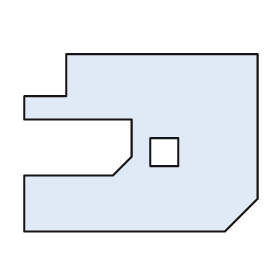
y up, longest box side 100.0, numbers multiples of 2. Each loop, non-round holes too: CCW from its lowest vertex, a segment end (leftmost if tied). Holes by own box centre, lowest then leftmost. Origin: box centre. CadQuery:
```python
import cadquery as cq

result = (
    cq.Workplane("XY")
    .moveTo(-50.0, -38.0)
    .lineTo(36.0, -38.0)
    .lineTo(50.0, -24.0)
    .lineTo(50.0, 38.0)
    .lineTo(-32.0, 38.0)
    .lineTo(-32.0, 20.0)
    .lineTo(-50.0, 20.0)
    .lineTo(-50.0, 10.0)
    .lineTo(-4.0, 10.0)
    .lineTo(-4.0, -6.0)
    .lineTo(-12.0, -14.0)
    .lineTo(-50.0, -14.0)
    .close()
    .moveTo(4.0, -10.0)
    .lineTo(16.0, -10.0)
    .lineTo(16.0, 2.0)
    .lineTo(4.0, 2.0)
    .close()
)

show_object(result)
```